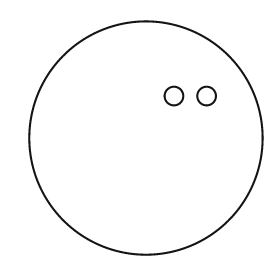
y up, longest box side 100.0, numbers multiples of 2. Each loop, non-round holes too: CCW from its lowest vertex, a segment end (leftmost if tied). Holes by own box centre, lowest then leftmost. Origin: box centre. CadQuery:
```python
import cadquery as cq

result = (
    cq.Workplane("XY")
    .moveTo(0.0, 0.0)
    .circle(50.0)
    .moveTo(12.0, 18.0)
    .circle(4.0)
    .moveTo(26.0, 18.0)
    .circle(4.0)
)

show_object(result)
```